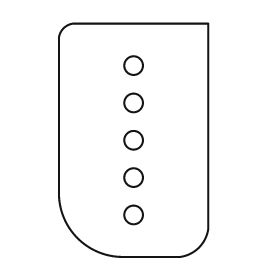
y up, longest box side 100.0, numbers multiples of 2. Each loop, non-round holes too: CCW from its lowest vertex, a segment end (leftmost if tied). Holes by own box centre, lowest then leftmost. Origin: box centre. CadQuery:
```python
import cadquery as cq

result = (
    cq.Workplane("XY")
    .moveTo(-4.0, -50.0)
    .lineTo(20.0, -50.0)
    .threePointArc((28.0, -46.0), (32.0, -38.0))
    .lineTo(32.0, 50.0)
    .lineTo(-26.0, 50.0)
    .threePointArc((-30.0, 48.0), (-32.0, 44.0))
    .lineTo(-32.0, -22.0)
    .threePointArc((-24.0, -42.0), (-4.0, -50.0))
    .close()
    .moveTo(0.0, -32.0)
    .circle(4.0)
    .moveTo(0.0, -16.0)
    .circle(4.0)
    .moveTo(0.0, 0.0)
    .circle(4.0)
    .moveTo(0.0, 16.0)
    .circle(4.0)
    .moveTo(0.0, 32.0)
    .circle(4.0)
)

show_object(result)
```